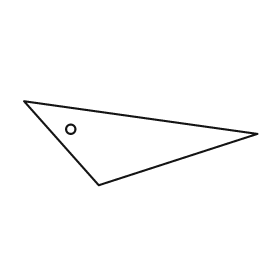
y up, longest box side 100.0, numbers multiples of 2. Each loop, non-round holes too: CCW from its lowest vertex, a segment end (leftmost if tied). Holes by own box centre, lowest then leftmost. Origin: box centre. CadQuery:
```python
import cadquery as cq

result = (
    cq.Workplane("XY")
    .moveTo(-18.0, -18.0)
    .lineTo(50.0, 4.0)
    .lineTo(-50.0, 18.0)
    .close()
    .moveTo(-30.0, 6.0)
    .circle(2.0)
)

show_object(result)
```